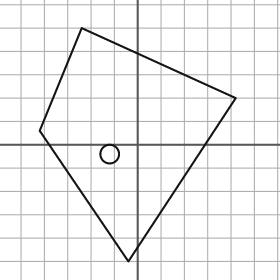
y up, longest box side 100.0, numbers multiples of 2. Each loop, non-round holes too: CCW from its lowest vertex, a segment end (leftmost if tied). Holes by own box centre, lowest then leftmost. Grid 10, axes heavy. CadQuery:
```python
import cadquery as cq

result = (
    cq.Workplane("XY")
    .moveTo(-4.0, -50.0)
    .lineTo(42.0, 20.0)
    .lineTo(-24.0, 50.0)
    .lineTo(-42.0, 6.0)
    .close()
    .moveTo(-12.0, -4.0)
    .circle(4.0)
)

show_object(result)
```